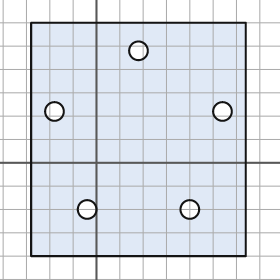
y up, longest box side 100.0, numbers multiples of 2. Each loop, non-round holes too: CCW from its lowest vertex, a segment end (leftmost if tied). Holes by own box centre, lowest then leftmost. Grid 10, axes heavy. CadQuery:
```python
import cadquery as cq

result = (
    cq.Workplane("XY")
    .moveTo(-28.0, -40.0)
    .lineTo(64.0, -40.0)
    .lineTo(64.0, 60.0)
    .lineTo(-28.0, 60.0)
    .close()
    .moveTo(-4.0, -20.0)
    .circle(4.0)
    .moveTo(40.0, -20.0)
    .circle(4.0)
    .moveTo(-18.0, 22.0)
    .circle(4.0)
    .moveTo(54.0, 22.0)
    .circle(4.0)
    .moveTo(18.0, 48.0)
    .circle(4.0)
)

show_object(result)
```